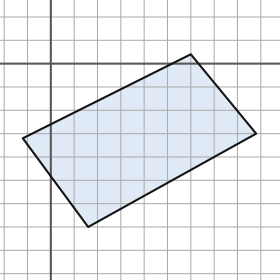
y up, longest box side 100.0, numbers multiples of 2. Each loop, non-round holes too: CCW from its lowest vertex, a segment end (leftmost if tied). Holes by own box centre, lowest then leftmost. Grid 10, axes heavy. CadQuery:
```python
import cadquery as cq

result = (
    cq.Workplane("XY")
    .moveTo(16.0, -70.0)
    .lineTo(88.0, -30.0)
    .lineTo(60.0, 4.0)
    .lineTo(-12.0, -32.0)
    .close()
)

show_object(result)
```